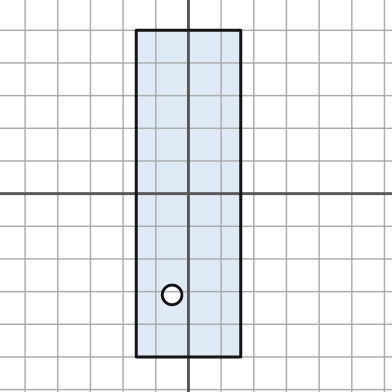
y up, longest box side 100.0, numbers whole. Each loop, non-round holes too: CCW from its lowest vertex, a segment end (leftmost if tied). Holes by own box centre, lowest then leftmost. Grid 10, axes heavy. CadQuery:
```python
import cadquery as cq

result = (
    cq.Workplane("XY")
    .moveTo(-16.0, -50.0)
    .lineTo(16.0, -50.0)
    .lineTo(16.0, 50.0)
    .lineTo(-16.0, 50.0)
    .close()
    .moveTo(-5.0, -31.0)
    .circle(3.0)
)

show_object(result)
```